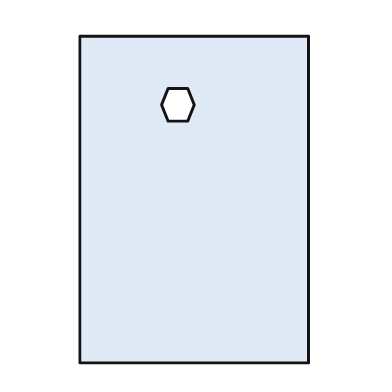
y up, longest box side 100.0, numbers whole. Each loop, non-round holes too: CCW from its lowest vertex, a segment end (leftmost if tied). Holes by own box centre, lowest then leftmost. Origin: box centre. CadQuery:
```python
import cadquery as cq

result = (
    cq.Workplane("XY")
    .moveTo(-35.0, -50.0)
    .lineTo(35.0, -50.0)
    .lineTo(35.0, 50.0)
    .lineTo(-35.0, 50.0)
    .close()
    .moveTo(-8.0, 24.0)
    .lineTo(-2.0, 24.0)
    .lineTo(0.0, 29.0)
    .lineTo(-2.0, 34.0)
    .lineTo(-8.0, 34.0)
    .lineTo(-10.0, 29.0)
    .close()
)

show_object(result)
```